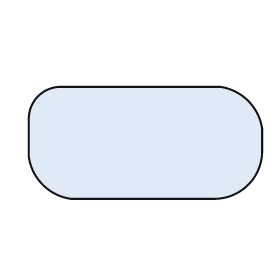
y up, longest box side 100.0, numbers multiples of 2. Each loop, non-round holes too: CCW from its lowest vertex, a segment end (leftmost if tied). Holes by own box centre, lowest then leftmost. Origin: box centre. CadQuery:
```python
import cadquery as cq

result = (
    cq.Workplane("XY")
    .moveTo(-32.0, -24.0)
    .lineTo(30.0, -24.0)
    .threePointArc((44.0, -18.0), (50.0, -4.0))
    .lineTo(50.0, 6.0)
    .threePointArc((44.0, 18.0), (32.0, 24.0))
    .lineTo(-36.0, 24.0)
    .threePointArc((-46.0, 20.0), (-50.0, 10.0))
    .lineTo(-50.0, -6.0)
    .threePointArc((-44.0, -18.0), (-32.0, -24.0))
    .close()
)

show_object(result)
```